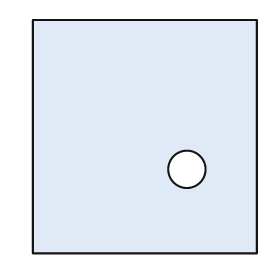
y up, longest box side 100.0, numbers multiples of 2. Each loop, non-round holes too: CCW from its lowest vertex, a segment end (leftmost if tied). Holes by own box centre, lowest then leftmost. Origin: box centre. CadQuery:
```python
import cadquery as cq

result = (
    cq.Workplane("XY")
    .moveTo(-48.0, -50.0)
    .lineTo(48.0, -50.0)
    .lineTo(48.0, 50.0)
    .lineTo(-48.0, 50.0)
    .close()
    .moveTo(18.0, -14.0)
    .circle(8.0)
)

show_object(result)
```